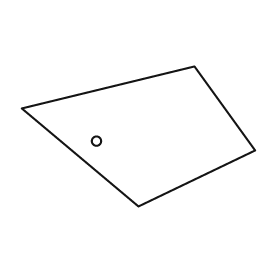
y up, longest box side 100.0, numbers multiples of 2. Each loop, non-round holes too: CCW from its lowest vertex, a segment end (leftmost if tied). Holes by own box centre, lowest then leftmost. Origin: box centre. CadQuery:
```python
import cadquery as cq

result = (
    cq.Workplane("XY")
    .moveTo(0.0, -30.0)
    .lineTo(50.0, -6.0)
    .lineTo(24.0, 30.0)
    .lineTo(-50.0, 12.0)
    .close()
    .moveTo(-18.0, -2.0)
    .circle(2.0)
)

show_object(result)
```